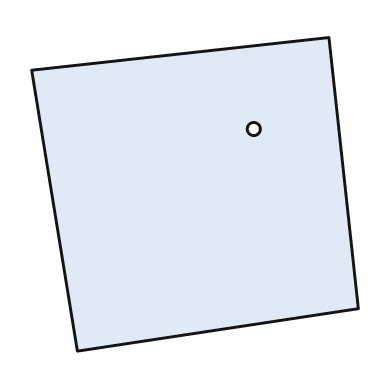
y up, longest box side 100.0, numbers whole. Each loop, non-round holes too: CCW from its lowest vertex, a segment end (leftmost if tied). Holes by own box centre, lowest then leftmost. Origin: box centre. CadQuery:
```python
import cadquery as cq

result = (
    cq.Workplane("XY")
    .moveTo(-36.0, -48.0)
    .lineTo(50.0, -35.0)
    .lineTo(41.0, 48.0)
    .lineTo(-50.0, 38.0)
    .close()
    .moveTo(18.0, 20.0)
    .circle(2.0)
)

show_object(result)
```